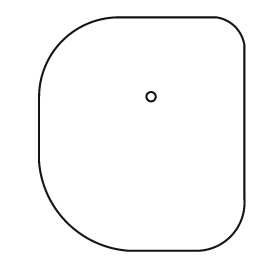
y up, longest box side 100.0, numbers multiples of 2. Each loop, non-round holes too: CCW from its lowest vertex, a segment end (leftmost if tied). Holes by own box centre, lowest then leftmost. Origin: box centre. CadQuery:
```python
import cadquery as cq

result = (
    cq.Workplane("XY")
    .moveTo(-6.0, -50.0)
    .lineTo(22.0, -50.0)
    .threePointArc((38.0, -44.0), (44.0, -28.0))
    .lineTo(44.0, 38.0)
    .threePointArc((40.0, 46.0), (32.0, 50.0))
    .lineTo(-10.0, 50.0)
    .threePointArc((-34.0, 40.0), (-44.0, 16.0))
    .lineTo(-44.0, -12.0)
    .threePointArc((-32.0, -38.0), (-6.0, -50.0))
    .close()
    .moveTo(4.0, 16.0)
    .circle(2.0)
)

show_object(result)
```